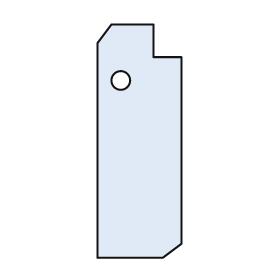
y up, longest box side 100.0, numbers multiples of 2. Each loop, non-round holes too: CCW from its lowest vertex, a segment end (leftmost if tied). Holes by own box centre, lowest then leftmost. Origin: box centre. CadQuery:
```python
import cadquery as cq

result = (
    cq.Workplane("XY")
    .moveTo(-18.0, -50.0)
    .lineTo(10.0, -50.0)
    .lineTo(18.0, -44.0)
    .lineTo(18.0, 36.0)
    .lineTo(6.0, 36.0)
    .lineTo(6.0, 50.0)
    .lineTo(-12.0, 50.0)
    .lineTo(-18.0, 42.0)
    .close()
    .moveTo(-8.0, 26.0)
    .circle(4.0)
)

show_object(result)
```